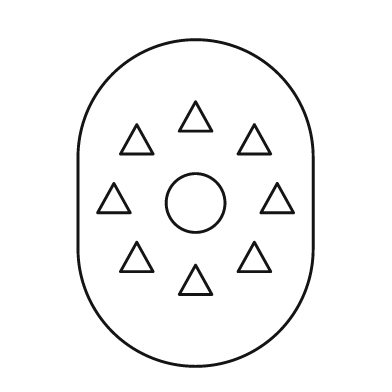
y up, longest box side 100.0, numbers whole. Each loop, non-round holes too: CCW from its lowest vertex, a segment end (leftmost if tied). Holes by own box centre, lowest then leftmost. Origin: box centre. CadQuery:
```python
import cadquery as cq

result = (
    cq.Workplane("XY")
    .moveTo(-36.0, -14.0)
    .threePointArc((0.0, -50.0), (36.0, -14.0))
    .lineTo(36.0, 14.0)
    .threePointArc((0.0, 50.0), (-36.0, 14.0))
    .close()
    .moveTo(-5.0, -28.0)
    .lineTo(5.0, -28.0)
    .lineTo(0.0, -19.0)
    .close()
    .moveTo(-23.0, -21.0)
    .lineTo(-13.0, -21.0)
    .lineTo(-18.0, -12.0)
    .close()
    .moveTo(13.0, -21.0)
    .lineTo(23.0, -21.0)
    .lineTo(18.0, -12.0)
    .close()
    .moveTo(0.0, 0.0)
    .circle(9.0)
    .moveTo(-30.0, -3.0)
    .lineTo(-20.0, -3.0)
    .lineTo(-25.0, 6.0)
    .close()
    .moveTo(20.0, -3.0)
    .lineTo(30.0, -3.0)
    .lineTo(25.0, 6.0)
    .close()
    .moveTo(-23.0, 15.0)
    .lineTo(-13.0, 15.0)
    .lineTo(-18.0, 24.0)
    .close()
    .moveTo(13.0, 15.0)
    .lineTo(23.0, 15.0)
    .lineTo(18.0, 24.0)
    .close()
    .moveTo(-5.0, 22.0)
    .lineTo(5.0, 22.0)
    .lineTo(0.0, 31.0)
    .close()
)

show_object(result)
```